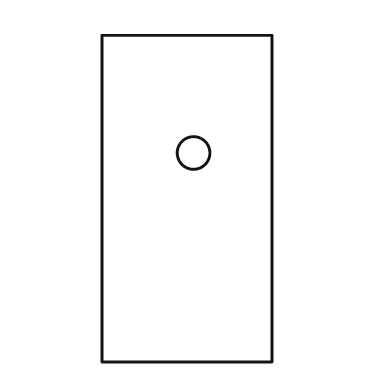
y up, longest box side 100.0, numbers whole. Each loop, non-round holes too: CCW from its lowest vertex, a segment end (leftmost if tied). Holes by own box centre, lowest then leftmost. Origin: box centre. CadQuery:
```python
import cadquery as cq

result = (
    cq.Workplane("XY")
    .moveTo(-26.0, -50.0)
    .lineTo(26.0, -50.0)
    .lineTo(26.0, 50.0)
    .lineTo(-26.0, 50.0)
    .close()
    .moveTo(2.0, 14.0)
    .circle(5.0)
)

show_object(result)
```